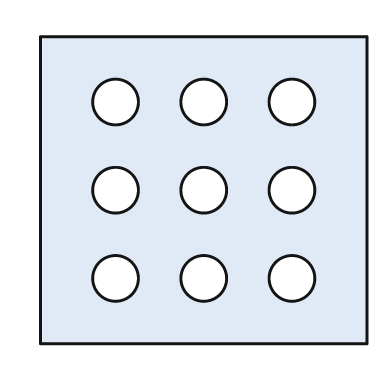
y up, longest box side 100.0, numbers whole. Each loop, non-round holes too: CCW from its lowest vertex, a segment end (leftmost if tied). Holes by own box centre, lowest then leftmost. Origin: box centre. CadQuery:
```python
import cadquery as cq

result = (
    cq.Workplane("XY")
    .moveTo(-50.0, -47.0)
    .lineTo(50.0, -47.0)
    .lineTo(50.0, 47.0)
    .lineTo(-50.0, 47.0)
    .close()
    .moveTo(-27.0, -27.0)
    .circle(7.0)
    .moveTo(0.0, -27.0)
    .circle(7.0)
    .moveTo(27.0, -27.0)
    .circle(7.0)
    .moveTo(-27.0, 0.0)
    .circle(7.0)
    .moveTo(0.0, 0.0)
    .circle(7.0)
    .moveTo(27.0, 0.0)
    .circle(7.0)
    .moveTo(-27.0, 27.0)
    .circle(7.0)
    .moveTo(0.0, 27.0)
    .circle(7.0)
    .moveTo(27.0, 27.0)
    .circle(7.0)
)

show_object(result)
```